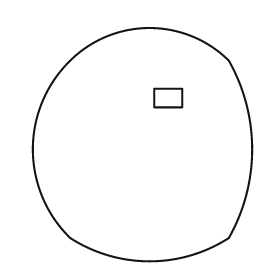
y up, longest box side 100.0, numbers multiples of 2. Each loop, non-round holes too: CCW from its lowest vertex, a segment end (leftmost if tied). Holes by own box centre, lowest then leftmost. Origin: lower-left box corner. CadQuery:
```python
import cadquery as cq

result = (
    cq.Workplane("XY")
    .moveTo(16.0, 10.0)
    .threePointArc((50.0, 0.0), (84.0, 10.0))
    .threePointArc((94.0, 48.0), (84.0, 86.0))
    .threePointArc((50.0, 100.0), (16.0, 86.0))
    .threePointArc((0.0, 48.0), (16.0, 10.0))
    .close()
    .moveTo(52.0, 66.0)
    .lineTo(64.0, 66.0)
    .lineTo(64.0, 74.0)
    .lineTo(52.0, 74.0)
    .close()
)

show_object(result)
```